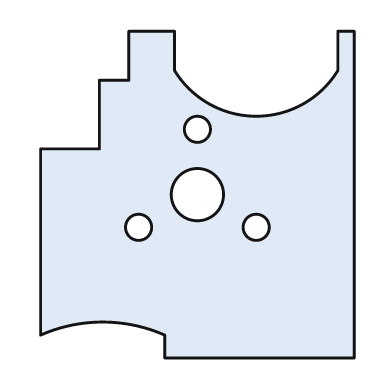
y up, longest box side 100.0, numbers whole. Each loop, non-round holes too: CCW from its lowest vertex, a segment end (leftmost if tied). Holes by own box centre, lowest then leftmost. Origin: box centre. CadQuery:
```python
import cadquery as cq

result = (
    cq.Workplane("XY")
    .moveTo(-10.0, -50.0)
    .lineTo(48.0, -50.0)
    .lineTo(48.0, 50.0)
    .lineTo(43.0, 50.0)
    .lineTo(43.0, 38.0)
    .threePointArc((18.0, 24.0), (-7.0, 38.0))
    .lineTo(-7.0, 50.0)
    .lineTo(-21.0, 50.0)
    .lineTo(-21.0, 35.0)
    .lineTo(-30.0, 35.0)
    .lineTo(-30.0, 14.0)
    .lineTo(-48.0, 14.0)
    .lineTo(-48.0, -43.0)
    .threePointArc((-29.0, -39.0), (-10.0, -43.0))
    .close()
    .moveTo(-18.0, -10.0)
    .circle(4.0)
    .moveTo(18.0, -10.0)
    .circle(4.0)
    .moveTo(0.0, 0.0)
    .circle(8.0)
    .moveTo(0.0, 20.0)
    .circle(4.0)
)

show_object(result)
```